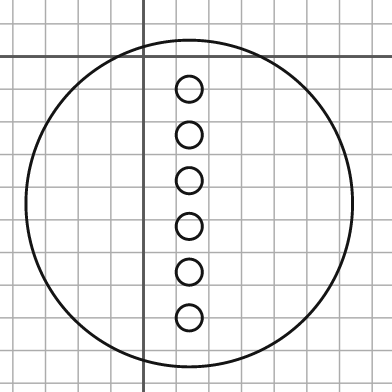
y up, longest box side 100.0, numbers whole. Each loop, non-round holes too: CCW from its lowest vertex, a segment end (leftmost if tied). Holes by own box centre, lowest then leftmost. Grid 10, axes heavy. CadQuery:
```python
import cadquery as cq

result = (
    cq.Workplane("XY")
    .moveTo(14.0, -45.0)
    .circle(50.0)
    .moveTo(14.0, -80.0)
    .circle(4.0)
    .moveTo(14.0, -66.0)
    .circle(4.0)
    .moveTo(14.0, -52.0)
    .circle(4.0)
    .moveTo(14.0, -38.0)
    .circle(4.0)
    .moveTo(14.0, -24.0)
    .circle(4.0)
    .moveTo(14.0, -10.0)
    .circle(4.0)
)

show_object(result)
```